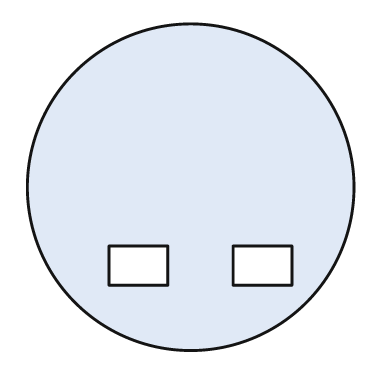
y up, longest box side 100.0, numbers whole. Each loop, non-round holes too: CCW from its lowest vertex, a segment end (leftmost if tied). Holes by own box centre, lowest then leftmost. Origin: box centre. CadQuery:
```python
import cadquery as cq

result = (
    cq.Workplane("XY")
    .moveTo(0.0, 0.0)
    .circle(50.0)
    .moveTo(-25.0, -30.0)
    .lineTo(-7.0, -30.0)
    .lineTo(-7.0, -18.0)
    .lineTo(-25.0, -18.0)
    .close()
    .moveTo(13.0, -30.0)
    .lineTo(31.0, -30.0)
    .lineTo(31.0, -18.0)
    .lineTo(13.0, -18.0)
    .close()
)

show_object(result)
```